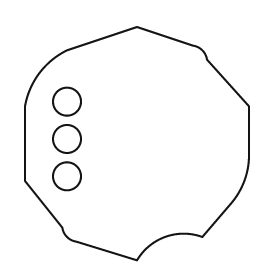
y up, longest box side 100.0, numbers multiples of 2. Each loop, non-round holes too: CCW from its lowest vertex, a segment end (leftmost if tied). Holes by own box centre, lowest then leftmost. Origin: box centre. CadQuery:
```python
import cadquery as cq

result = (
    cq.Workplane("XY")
    .moveTo(0.0, -50.0)
    .threePointArc((12.0, -40.0), (28.0, -40.0))
    .lineTo(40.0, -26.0)
    .threePointArc((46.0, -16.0), (48.0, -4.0))
    .lineTo(48.0, 16.0)
    .lineTo(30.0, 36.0)
    .threePointArc((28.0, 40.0), (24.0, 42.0))
    .lineTo(0.0, 50.0)
    .lineTo(-30.0, 40.0)
    .threePointArc((-42.0, 30.0), (-48.0, 16.0))
    .lineTo(-48.0, -16.0)
    .lineTo(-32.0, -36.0)
    .threePointArc((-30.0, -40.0), (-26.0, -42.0))
    .close()
    .moveTo(-30.0, -14.0)
    .circle(6.0)
    .moveTo(-30.0, 2.0)
    .circle(6.0)
    .moveTo(-30.0, 18.0)
    .circle(6.0)
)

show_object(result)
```